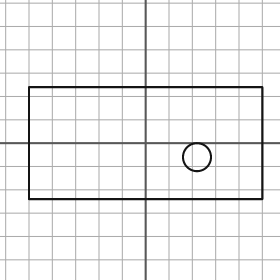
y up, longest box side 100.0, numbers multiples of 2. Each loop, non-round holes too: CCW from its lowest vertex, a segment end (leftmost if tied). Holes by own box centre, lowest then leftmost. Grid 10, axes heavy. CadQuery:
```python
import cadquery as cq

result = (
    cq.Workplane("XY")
    .moveTo(-50.0, -24.0)
    .lineTo(50.0, -24.0)
    .lineTo(50.0, 24.0)
    .lineTo(-50.0, 24.0)
    .close()
    .moveTo(22.0, -6.0)
    .circle(6.0)
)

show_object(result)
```